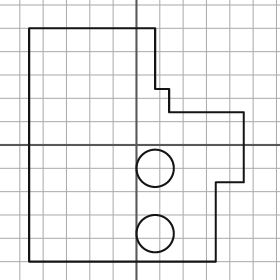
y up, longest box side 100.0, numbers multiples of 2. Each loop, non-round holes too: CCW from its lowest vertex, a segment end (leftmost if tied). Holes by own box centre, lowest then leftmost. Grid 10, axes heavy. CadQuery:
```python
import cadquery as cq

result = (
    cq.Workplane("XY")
    .moveTo(-46.0, -50.0)
    .lineTo(34.0, -50.0)
    .lineTo(34.0, -16.0)
    .lineTo(46.0, -16.0)
    .lineTo(46.0, 14.0)
    .lineTo(14.0, 14.0)
    .lineTo(14.0, 24.0)
    .lineTo(8.0, 24.0)
    .lineTo(8.0, 50.0)
    .lineTo(-46.0, 50.0)
    .close()
    .moveTo(8.0, -38.0)
    .circle(8.0)
    .moveTo(8.0, -10.0)
    .circle(8.0)
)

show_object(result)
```